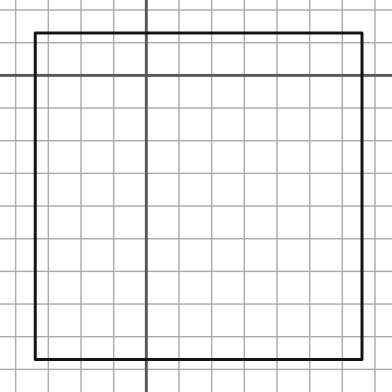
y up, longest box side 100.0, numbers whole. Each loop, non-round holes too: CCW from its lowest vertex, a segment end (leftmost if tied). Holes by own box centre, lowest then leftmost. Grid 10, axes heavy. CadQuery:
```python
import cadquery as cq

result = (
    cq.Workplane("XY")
    .moveTo(-34.0, -87.0)
    .lineTo(66.0, -87.0)
    .lineTo(66.0, 13.0)
    .lineTo(-34.0, 13.0)
    .close()
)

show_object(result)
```